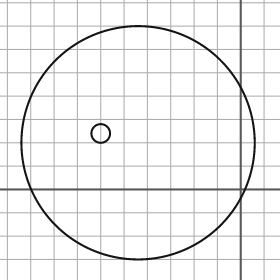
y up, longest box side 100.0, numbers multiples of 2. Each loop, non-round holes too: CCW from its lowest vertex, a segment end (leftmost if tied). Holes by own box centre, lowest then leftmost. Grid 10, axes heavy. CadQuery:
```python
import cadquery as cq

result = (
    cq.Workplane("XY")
    .moveTo(-44.0, 20.0)
    .circle(50.0)
    .moveTo(-60.0, 24.0)
    .circle(4.0)
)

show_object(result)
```